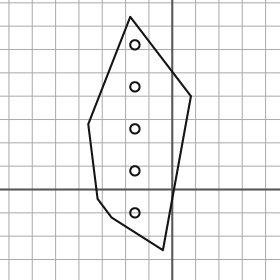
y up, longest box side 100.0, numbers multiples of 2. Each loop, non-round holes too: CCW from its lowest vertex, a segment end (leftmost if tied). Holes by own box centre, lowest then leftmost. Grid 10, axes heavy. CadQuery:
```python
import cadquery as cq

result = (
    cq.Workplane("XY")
    .moveTo(-4.0, -26.0)
    .lineTo(8.0, 40.0)
    .lineTo(-18.0, 74.0)
    .lineTo(-36.0, 28.0)
    .lineTo(-32.0, -4.0)
    .lineTo(-26.0, -12.0)
    .close()
    .moveTo(-16.0, -10.0)
    .circle(2.0)
    .moveTo(-16.0, 8.0)
    .circle(2.0)
    .moveTo(-16.0, 26.0)
    .circle(2.0)
    .moveTo(-16.0, 44.0)
    .circle(2.0)
    .moveTo(-16.0, 62.0)
    .circle(2.0)
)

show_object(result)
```